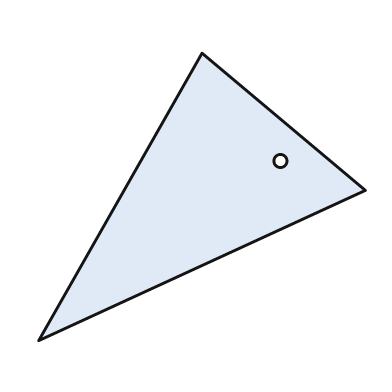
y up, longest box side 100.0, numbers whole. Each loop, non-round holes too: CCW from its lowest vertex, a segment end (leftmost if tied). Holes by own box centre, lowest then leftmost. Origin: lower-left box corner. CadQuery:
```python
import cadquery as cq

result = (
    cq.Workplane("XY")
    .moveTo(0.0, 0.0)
    .lineTo(100.0, 46.0)
    .lineTo(50.0, 88.0)
    .close()
    .moveTo(74.0, 55.0)
    .circle(2.0)
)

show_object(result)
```